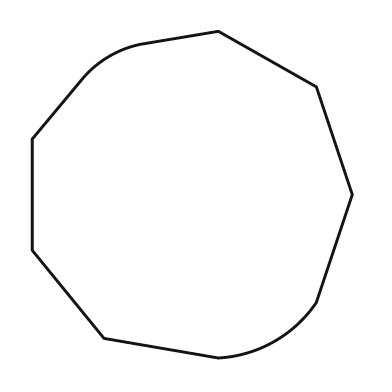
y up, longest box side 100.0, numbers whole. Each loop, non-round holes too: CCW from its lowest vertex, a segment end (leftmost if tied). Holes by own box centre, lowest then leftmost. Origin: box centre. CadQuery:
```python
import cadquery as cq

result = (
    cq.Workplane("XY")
    .moveTo(8.0, -50.0)
    .threePointArc((25.0, -45.0), (38.0, -33.0))
    .lineTo(49.0, 0.0)
    .lineTo(38.0, 33.0)
    .lineTo(8.0, 50.0)
    .lineTo(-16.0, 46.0)
    .threePointArc((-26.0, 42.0), (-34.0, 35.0))
    .lineTo(-49.0, 17.0)
    .lineTo(-49.0, -17.0)
    .lineTo(-27.0, -44.0)
    .close()
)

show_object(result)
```